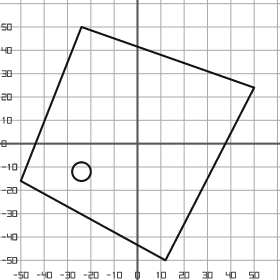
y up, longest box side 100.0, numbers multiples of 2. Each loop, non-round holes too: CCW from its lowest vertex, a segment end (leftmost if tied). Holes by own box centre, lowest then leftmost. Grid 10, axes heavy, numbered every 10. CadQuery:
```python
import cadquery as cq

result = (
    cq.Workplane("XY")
    .moveTo(12.0, -50.0)
    .lineTo(50.0, 24.0)
    .lineTo(-24.0, 50.0)
    .lineTo(-50.0, -16.0)
    .close()
    .moveTo(-24.0, -12.0)
    .circle(4.0)
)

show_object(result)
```